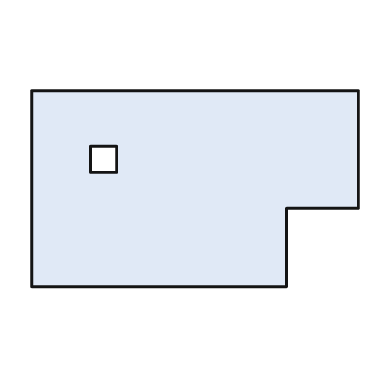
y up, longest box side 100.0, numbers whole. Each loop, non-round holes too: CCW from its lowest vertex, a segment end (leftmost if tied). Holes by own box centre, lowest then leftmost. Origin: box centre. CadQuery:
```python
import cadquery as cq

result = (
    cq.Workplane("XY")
    .moveTo(-50.0, -30.0)
    .lineTo(28.0, -30.0)
    .lineTo(28.0, -6.0)
    .lineTo(50.0, -6.0)
    .lineTo(50.0, 30.0)
    .lineTo(-50.0, 30.0)
    .close()
    .moveTo(-32.0, 5.0)
    .lineTo(-24.0, 5.0)
    .lineTo(-24.0, 13.0)
    .lineTo(-32.0, 13.0)
    .close()
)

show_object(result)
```